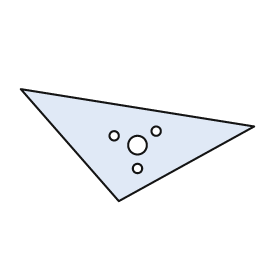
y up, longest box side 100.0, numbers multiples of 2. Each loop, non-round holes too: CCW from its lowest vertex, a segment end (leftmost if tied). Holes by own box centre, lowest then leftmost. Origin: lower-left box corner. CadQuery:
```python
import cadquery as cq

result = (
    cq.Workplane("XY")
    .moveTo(42.0, 0.0)
    .lineTo(100.0, 32.0)
    .lineTo(0.0, 48.0)
    .close()
    .moveTo(50.0, 14.0)
    .circle(2.0)
    .moveTo(50.0, 24.0)
    .circle(4.0)
    .moveTo(40.0, 28.0)
    .circle(2.0)
    .moveTo(58.0, 30.0)
    .circle(2.0)
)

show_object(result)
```